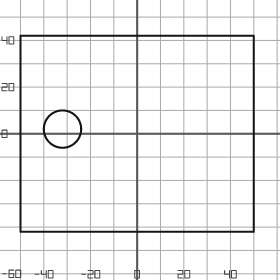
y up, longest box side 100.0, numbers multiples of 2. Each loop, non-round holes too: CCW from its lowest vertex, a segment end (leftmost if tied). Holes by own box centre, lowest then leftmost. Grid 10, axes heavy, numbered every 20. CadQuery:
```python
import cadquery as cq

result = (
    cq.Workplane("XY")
    .moveTo(-50.0, -42.0)
    .lineTo(50.0, -42.0)
    .lineTo(50.0, 42.0)
    .lineTo(-50.0, 42.0)
    .close()
    .moveTo(-32.0, 2.0)
    .circle(8.0)
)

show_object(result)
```